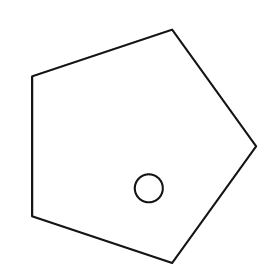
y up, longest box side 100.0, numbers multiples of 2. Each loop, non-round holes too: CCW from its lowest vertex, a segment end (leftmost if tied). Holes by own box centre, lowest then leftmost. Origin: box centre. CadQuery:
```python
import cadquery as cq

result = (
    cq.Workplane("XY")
    .moveTo(12.0, -50.0)
    .lineTo(48.0, 0.0)
    .lineTo(12.0, 50.0)
    .lineTo(-48.0, 30.0)
    .lineTo(-48.0, -30.0)
    .close()
    .moveTo(2.0, -18.0)
    .circle(6.0)
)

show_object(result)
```